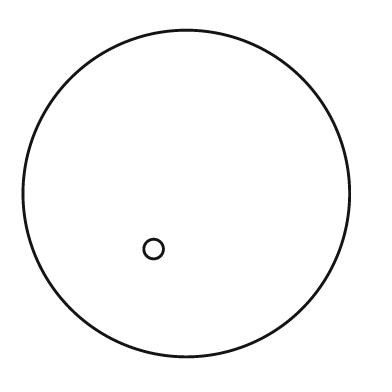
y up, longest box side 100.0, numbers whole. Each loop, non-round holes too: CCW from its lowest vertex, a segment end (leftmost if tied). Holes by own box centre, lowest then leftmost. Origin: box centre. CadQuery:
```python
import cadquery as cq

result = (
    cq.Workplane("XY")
    .moveTo(0.0, 0.0)
    .circle(50.0)
    .moveTo(-10.0, -17.0)
    .circle(3.0)
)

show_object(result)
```